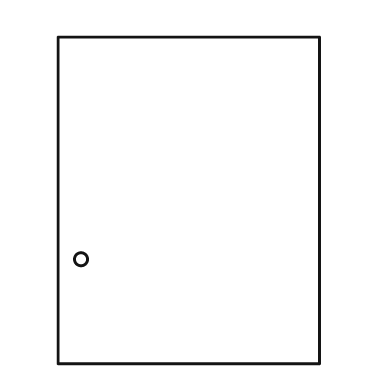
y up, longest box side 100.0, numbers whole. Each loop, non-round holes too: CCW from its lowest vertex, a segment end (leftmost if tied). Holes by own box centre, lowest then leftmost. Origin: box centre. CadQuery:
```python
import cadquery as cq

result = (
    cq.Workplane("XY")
    .moveTo(-40.0, -50.0)
    .lineTo(40.0, -50.0)
    .lineTo(40.0, 50.0)
    .lineTo(-40.0, 50.0)
    .close()
    .moveTo(-33.0, -18.0)
    .circle(2.0)
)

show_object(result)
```